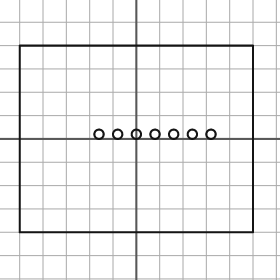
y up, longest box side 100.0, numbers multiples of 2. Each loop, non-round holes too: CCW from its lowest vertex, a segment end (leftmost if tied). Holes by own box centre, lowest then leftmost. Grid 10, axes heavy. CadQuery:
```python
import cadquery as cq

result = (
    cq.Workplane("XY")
    .moveTo(-50.0, -40.0)
    .lineTo(50.0, -40.0)
    .lineTo(50.0, 40.0)
    .lineTo(-50.0, 40.0)
    .close()
    .moveTo(-16.0, 2.0)
    .circle(2.0)
    .moveTo(-8.0, 2.0)
    .circle(2.0)
    .moveTo(0.0, 2.0)
    .circle(2.0)
    .moveTo(8.0, 2.0)
    .circle(2.0)
    .moveTo(16.0, 2.0)
    .circle(2.0)
    .moveTo(24.0, 2.0)
    .circle(2.0)
    .moveTo(32.0, 2.0)
    .circle(2.0)
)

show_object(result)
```